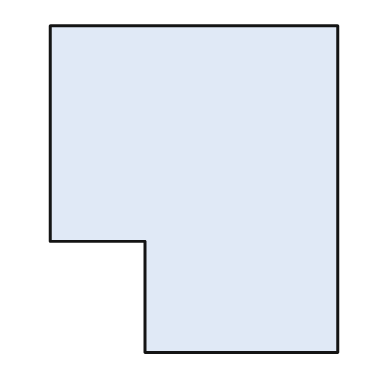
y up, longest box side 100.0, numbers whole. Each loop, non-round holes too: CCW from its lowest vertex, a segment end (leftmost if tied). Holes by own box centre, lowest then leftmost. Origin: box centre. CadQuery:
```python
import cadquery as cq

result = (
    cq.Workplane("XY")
    .moveTo(-15.0, -50.0)
    .lineTo(44.0, -50.0)
    .lineTo(44.0, 50.0)
    .lineTo(-44.0, 50.0)
    .lineTo(-44.0, -16.0)
    .lineTo(-15.0, -16.0)
    .close()
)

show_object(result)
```